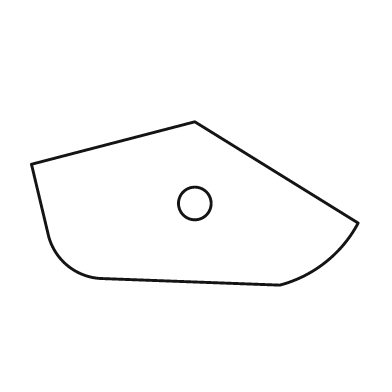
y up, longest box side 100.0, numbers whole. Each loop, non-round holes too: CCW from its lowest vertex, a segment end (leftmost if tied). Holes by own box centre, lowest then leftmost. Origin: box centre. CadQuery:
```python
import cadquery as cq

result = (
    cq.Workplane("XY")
    .moveTo(26.0, -25.0)
    .threePointArc((40.0, -18.0), (50.0, -6.0))
    .lineTo(0.0, 25.0)
    .lineTo(-50.0, 12.0)
    .lineTo(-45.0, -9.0)
    .threePointArc((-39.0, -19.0), (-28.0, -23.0))
    .close()
    .moveTo(0.0, 0.0)
    .circle(5.0)
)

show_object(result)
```